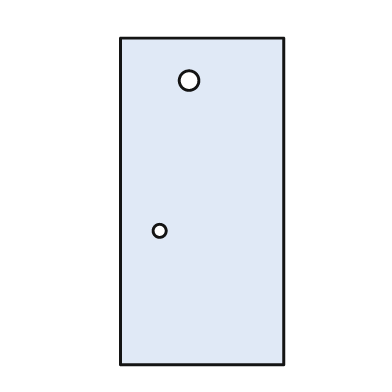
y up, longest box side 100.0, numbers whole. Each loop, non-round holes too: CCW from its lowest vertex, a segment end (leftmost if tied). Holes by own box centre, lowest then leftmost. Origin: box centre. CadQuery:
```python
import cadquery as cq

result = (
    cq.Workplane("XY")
    .moveTo(-25.0, -50.0)
    .lineTo(25.0, -50.0)
    .lineTo(25.0, 50.0)
    .lineTo(-25.0, 50.0)
    .close()
    .moveTo(-13.0, -9.0)
    .circle(2.0)
    .moveTo(-4.0, 37.0)
    .circle(3.0)
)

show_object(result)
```